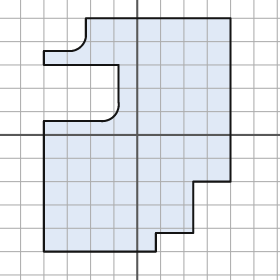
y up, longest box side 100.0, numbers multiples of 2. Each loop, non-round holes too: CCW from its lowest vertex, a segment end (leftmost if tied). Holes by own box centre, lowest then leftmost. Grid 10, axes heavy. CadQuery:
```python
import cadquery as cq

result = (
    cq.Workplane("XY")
    .moveTo(-40.0, -50.0)
    .lineTo(8.0, -50.0)
    .lineTo(8.0, -42.0)
    .lineTo(24.0, -42.0)
    .lineTo(24.0, -20.0)
    .lineTo(40.0, -20.0)
    .lineTo(40.0, 50.0)
    .lineTo(-22.0, 50.0)
    .lineTo(-22.0, 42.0)
    .threePointArc((-24.0, 38.0), (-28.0, 36.0))
    .lineTo(-40.0, 36.0)
    .lineTo(-40.0, 30.0)
    .lineTo(-8.0, 30.0)
    .lineTo(-8.0, 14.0)
    .threePointArc((-10.0, 8.0), (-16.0, 6.0))
    .lineTo(-40.0, 6.0)
    .close()
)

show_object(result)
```